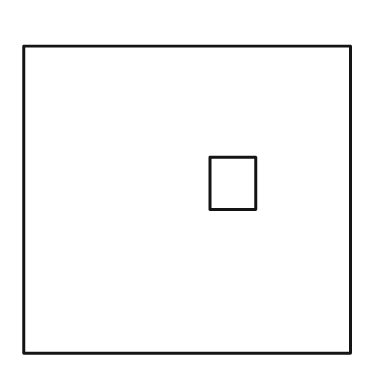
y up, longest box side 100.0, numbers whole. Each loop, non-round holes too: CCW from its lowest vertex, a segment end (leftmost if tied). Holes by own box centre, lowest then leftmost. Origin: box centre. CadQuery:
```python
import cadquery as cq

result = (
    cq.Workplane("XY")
    .moveTo(-50.0, -47.0)
    .lineTo(50.0, -47.0)
    .lineTo(50.0, 47.0)
    .lineTo(-50.0, 47.0)
    .close()
    .moveTo(7.0, -3.0)
    .lineTo(21.0, -3.0)
    .lineTo(21.0, 13.0)
    .lineTo(7.0, 13.0)
    .close()
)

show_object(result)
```